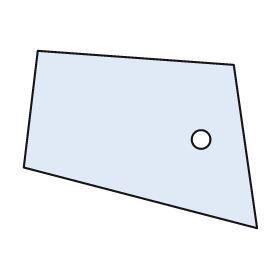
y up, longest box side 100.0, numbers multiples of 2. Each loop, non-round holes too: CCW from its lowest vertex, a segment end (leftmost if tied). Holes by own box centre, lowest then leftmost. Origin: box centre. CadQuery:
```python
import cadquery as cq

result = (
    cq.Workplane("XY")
    .moveTo(50.0, -38.0)
    .lineTo(40.0, 32.0)
    .lineTo(-44.0, 38.0)
    .lineTo(-50.0, -12.0)
    .close()
    .moveTo(26.0, 0.0)
    .circle(4.0)
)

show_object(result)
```